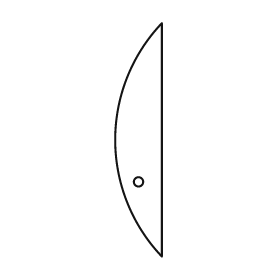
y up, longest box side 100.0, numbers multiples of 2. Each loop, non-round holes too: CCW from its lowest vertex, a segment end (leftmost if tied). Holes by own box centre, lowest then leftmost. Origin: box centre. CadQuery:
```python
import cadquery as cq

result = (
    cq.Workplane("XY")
    .moveTo(10.0, -50.0)
    .lineTo(10.0, 50.0)
    .threePointArc((-10.0, 0.0), (10.0, -50.0))
    .close()
    .moveTo(0.0, -18.0)
    .circle(2.0)
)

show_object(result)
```